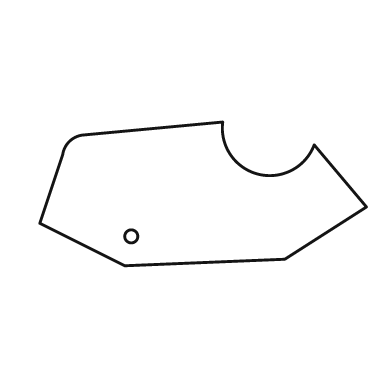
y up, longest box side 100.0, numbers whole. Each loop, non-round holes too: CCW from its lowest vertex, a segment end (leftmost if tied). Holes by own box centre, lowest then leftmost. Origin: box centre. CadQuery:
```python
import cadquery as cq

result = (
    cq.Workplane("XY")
    .moveTo(-24.0, -22.0)
    .lineTo(25.0, -20.0)
    .lineTo(50.0, -4.0)
    .lineTo(34.0, 15.0)
    .threePointArc((17.0, 6.0), (6.0, 22.0))
    .lineTo(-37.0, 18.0)
    .threePointArc((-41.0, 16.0), (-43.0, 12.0))
    .lineTo(-50.0, -9.0)
    .close()
    .moveTo(-22.0, -13.0)
    .circle(2.0)
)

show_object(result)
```